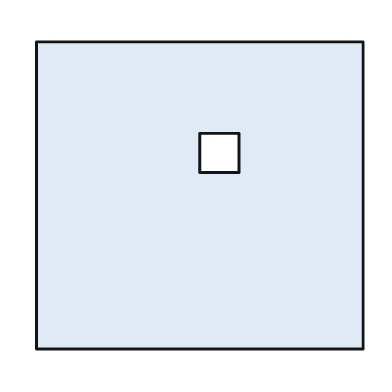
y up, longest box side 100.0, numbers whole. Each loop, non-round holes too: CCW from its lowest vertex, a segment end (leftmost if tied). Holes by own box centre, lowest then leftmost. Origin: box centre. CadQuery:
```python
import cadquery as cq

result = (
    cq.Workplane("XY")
    .moveTo(-50.0, -47.0)
    .lineTo(50.0, -47.0)
    .lineTo(50.0, 47.0)
    .lineTo(-50.0, 47.0)
    .close()
    .moveTo(0.0, 7.0)
    .lineTo(12.0, 7.0)
    .lineTo(12.0, 19.0)
    .lineTo(0.0, 19.0)
    .close()
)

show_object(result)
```